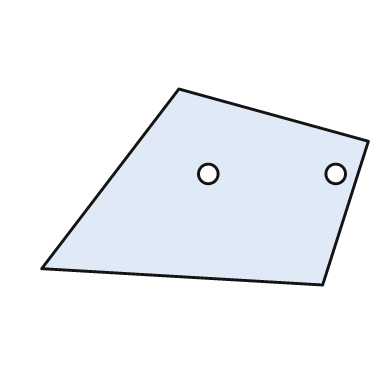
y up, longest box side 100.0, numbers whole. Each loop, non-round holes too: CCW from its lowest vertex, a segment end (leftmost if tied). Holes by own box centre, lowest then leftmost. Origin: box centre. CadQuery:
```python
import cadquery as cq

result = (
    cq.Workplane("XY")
    .moveTo(36.0, -30.0)
    .lineTo(50.0, 14.0)
    .lineTo(-8.0, 30.0)
    .lineTo(-50.0, -25.0)
    .close()
    .moveTo(1.0, 4.0)
    .circle(3.0)
    .moveTo(40.0, 4.0)
    .circle(3.0)
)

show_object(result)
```